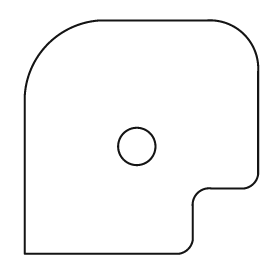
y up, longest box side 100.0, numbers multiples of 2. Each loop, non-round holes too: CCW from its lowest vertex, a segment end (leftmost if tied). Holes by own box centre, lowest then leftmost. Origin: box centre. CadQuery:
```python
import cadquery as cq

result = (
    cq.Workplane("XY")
    .moveTo(-50.0, -50.0)
    .lineTo(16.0, -50.0)
    .threePointArc((20.0, -48.0), (22.0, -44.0))
    .lineTo(22.0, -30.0)
    .threePointArc((24.0, -24.0), (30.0, -22.0))
    .lineTo(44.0, -22.0)
    .threePointArc((48.0, -20.0), (50.0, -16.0))
    .lineTo(50.0, 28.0)
    .threePointArc((44.0, 44.0), (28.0, 50.0))
    .lineTo(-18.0, 50.0)
    .threePointArc((-40.0, 40.0), (-50.0, 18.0))
    .close()
    .moveTo(-2.0, -4.0)
    .circle(8.0)
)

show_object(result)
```